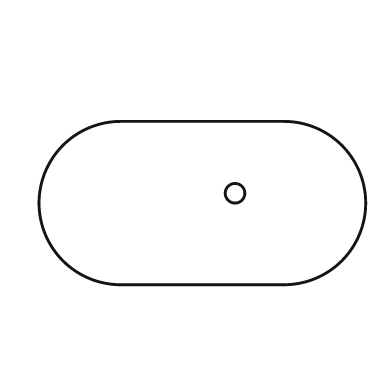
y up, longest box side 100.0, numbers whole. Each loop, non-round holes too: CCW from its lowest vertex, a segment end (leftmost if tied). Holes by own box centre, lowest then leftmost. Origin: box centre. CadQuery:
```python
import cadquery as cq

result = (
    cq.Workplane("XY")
    .moveTo(-25.0, -25.0)
    .lineTo(25.0, -25.0)
    .threePointArc((50.0, 0.0), (25.0, 25.0))
    .lineTo(-25.0, 25.0)
    .threePointArc((-50.0, 0.0), (-25.0, -25.0))
    .close()
    .moveTo(10.0, 3.0)
    .circle(3.0)
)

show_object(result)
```